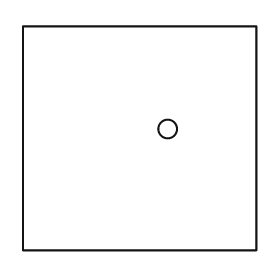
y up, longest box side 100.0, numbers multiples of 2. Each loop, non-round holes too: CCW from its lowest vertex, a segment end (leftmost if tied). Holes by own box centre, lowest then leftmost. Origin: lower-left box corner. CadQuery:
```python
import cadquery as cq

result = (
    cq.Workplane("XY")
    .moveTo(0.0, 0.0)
    .lineTo(100.0, 0.0)
    .lineTo(100.0, 96.0)
    .lineTo(0.0, 96.0)
    .close()
    .moveTo(62.0, 52.0)
    .circle(4.0)
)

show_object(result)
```